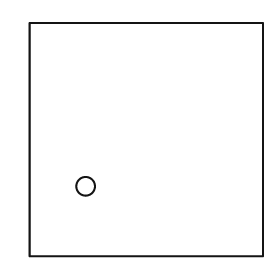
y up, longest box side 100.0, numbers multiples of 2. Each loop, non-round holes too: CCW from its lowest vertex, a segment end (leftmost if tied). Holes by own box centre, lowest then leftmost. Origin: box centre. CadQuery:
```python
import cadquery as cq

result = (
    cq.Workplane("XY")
    .moveTo(-50.0, -50.0)
    .lineTo(50.0, -50.0)
    .lineTo(50.0, 50.0)
    .lineTo(-50.0, 50.0)
    .close()
    .moveTo(-26.0, -20.0)
    .circle(4.0)
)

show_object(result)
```